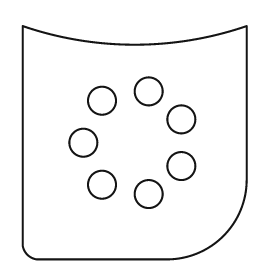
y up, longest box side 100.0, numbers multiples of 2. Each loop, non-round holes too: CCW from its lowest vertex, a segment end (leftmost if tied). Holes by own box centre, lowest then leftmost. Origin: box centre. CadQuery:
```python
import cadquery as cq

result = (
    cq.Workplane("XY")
    .moveTo(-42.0, -50.0)
    .lineTo(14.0, -50.0)
    .threePointArc((38.0, -40.0), (48.0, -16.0))
    .lineTo(48.0, 50.0)
    .threePointArc((0.0, 42.0), (-48.0, 50.0))
    .lineTo(-48.0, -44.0)
    .threePointArc((-46.0, -48.0), (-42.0, -50.0))
    .close()
    .moveTo(6.0, -22.0)
    .circle(6.0)
    .moveTo(-14.0, -18.0)
    .circle(6.0)
    .moveTo(20.0, -10.0)
    .circle(6.0)
    .moveTo(-22.0, 0.0)
    .circle(6.0)
    .moveTo(20.0, 10.0)
    .circle(6.0)
    .moveTo(-14.0, 18.0)
    .circle(6.0)
    .moveTo(6.0, 22.0)
    .circle(6.0)
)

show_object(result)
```